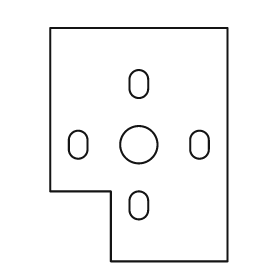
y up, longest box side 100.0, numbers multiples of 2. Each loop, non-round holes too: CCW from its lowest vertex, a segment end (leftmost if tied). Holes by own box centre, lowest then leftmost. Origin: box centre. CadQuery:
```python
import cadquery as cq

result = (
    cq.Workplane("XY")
    .moveTo(-12.0, -50.0)
    .lineTo(38.0, -50.0)
    .lineTo(38.0, 50.0)
    .lineTo(-38.0, 50.0)
    .lineTo(-38.0, -20.0)
    .lineTo(-12.0, -20.0)
    .close()
    .moveTo(-4.0, -28.0)
    .threePointArc((0.0, -32.0), (4.0, -28.0))
    .lineTo(4.0, -24.0)
    .threePointArc((0.0, -20.0), (-4.0, -24.0))
    .close()
    .moveTo(-30.0, -2.0)
    .threePointArc((-26.0, -6.0), (-22.0, -2.0))
    .lineTo(-22.0, 2.0)
    .threePointArc((-26.0, 6.0), (-30.0, 2.0))
    .close()
    .moveTo(0.0, 0.0)
    .circle(8.0)
    .moveTo(22.0, -2.0)
    .threePointArc((26.0, -6.0), (30.0, -2.0))
    .lineTo(30.0, 2.0)
    .threePointArc((26.0, 6.0), (22.0, 2.0))
    .close()
    .moveTo(-4.0, 24.0)
    .threePointArc((0.0, 20.0), (4.0, 24.0))
    .lineTo(4.0, 28.0)
    .threePointArc((0.0, 32.0), (-4.0, 28.0))
    .close()
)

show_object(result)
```